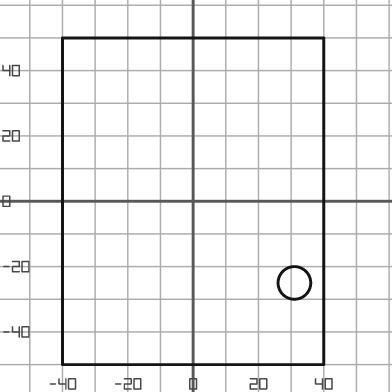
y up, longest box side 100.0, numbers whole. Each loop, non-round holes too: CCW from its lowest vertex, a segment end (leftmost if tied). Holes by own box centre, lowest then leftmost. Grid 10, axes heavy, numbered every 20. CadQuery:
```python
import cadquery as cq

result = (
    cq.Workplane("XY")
    .moveTo(-40.0, -50.0)
    .lineTo(40.0, -50.0)
    .lineTo(40.0, 50.0)
    .lineTo(-40.0, 50.0)
    .close()
    .moveTo(31.0, -25.0)
    .circle(5.0)
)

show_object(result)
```